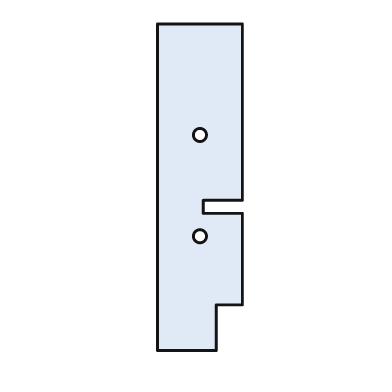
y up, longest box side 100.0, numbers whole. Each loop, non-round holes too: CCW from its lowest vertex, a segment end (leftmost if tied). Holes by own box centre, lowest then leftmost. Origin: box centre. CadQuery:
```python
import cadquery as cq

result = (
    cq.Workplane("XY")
    .moveTo(-13.0, -50.0)
    .lineTo(5.0, -50.0)
    .lineTo(5.0, -36.0)
    .lineTo(13.0, -36.0)
    .lineTo(13.0, -8.0)
    .lineTo(1.0, -8.0)
    .lineTo(1.0, -4.0)
    .lineTo(13.0, -4.0)
    .lineTo(13.0, 50.0)
    .lineTo(-13.0, 50.0)
    .close()
    .moveTo(0.0, -15.0)
    .circle(2.0)
    .moveTo(0.0, 16.0)
    .circle(2.0)
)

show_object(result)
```